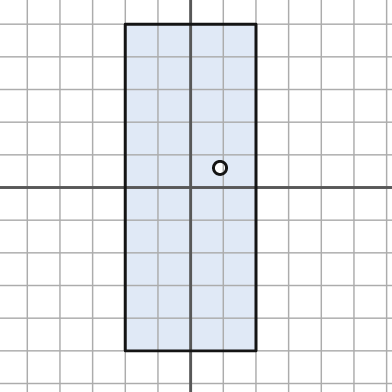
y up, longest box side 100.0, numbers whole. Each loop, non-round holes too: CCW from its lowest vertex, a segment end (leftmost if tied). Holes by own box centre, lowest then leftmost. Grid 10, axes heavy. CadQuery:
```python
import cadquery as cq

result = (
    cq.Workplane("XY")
    .moveTo(-20.0, -50.0)
    .lineTo(20.0, -50.0)
    .lineTo(20.0, 50.0)
    .lineTo(-20.0, 50.0)
    .close()
    .moveTo(9.0, 6.0)
    .circle(2.0)
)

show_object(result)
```